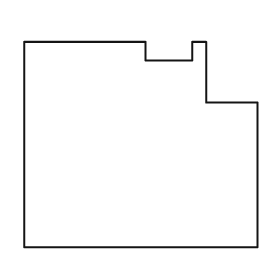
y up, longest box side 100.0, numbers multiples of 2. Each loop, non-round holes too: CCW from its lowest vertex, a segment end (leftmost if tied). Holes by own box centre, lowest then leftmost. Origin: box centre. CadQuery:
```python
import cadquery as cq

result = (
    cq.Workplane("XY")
    .moveTo(-50.0, -44.0)
    .lineTo(50.0, -44.0)
    .lineTo(50.0, 18.0)
    .lineTo(28.0, 18.0)
    .lineTo(28.0, 44.0)
    .lineTo(22.0, 44.0)
    .lineTo(22.0, 36.0)
    .lineTo(2.0, 36.0)
    .lineTo(2.0, 44.0)
    .lineTo(-50.0, 44.0)
    .close()
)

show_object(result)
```